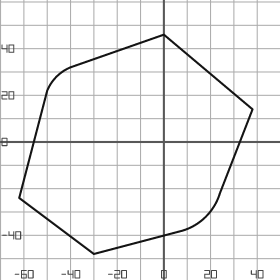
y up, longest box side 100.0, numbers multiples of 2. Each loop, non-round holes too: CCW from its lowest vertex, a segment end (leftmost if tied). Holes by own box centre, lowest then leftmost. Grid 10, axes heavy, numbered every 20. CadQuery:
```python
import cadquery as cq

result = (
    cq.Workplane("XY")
    .moveTo(-30.0, -48.0)
    .lineTo(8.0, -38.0)
    .threePointArc((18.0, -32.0), (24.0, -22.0))
    .lineTo(38.0, 14.0)
    .lineTo(0.0, 46.0)
    .lineTo(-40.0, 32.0)
    .threePointArc((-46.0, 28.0), (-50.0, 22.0))
    .lineTo(-62.0, -24.0)
    .close()
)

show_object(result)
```